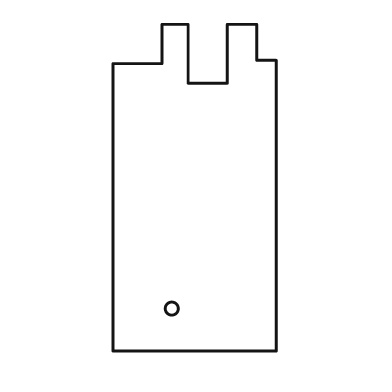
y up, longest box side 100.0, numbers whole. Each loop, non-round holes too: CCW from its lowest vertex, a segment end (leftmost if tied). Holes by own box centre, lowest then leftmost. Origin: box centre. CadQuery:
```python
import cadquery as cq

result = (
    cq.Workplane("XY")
    .moveTo(-25.0, -50.0)
    .lineTo(25.0, -50.0)
    .lineTo(25.0, 39.0)
    .lineTo(19.0, 39.0)
    .lineTo(19.0, 50.0)
    .lineTo(10.0, 50.0)
    .lineTo(10.0, 32.0)
    .lineTo(-2.0, 32.0)
    .lineTo(-2.0, 50.0)
    .lineTo(-10.0, 50.0)
    .lineTo(-10.0, 38.0)
    .lineTo(-25.0, 38.0)
    .close()
    .moveTo(-7.0, -37.0)
    .circle(2.0)
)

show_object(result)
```